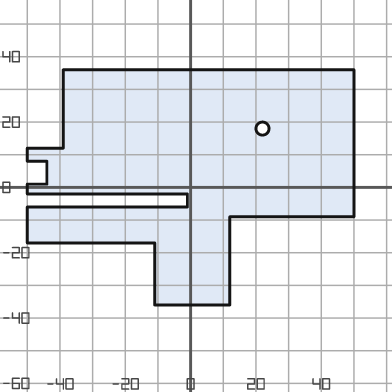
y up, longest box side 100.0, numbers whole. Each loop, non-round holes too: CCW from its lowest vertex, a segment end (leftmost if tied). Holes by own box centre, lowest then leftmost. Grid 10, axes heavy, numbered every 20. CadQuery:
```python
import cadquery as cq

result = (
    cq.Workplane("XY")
    .moveTo(-11.0, -36.0)
    .lineTo(12.0, -36.0)
    .lineTo(12.0, -9.0)
    .lineTo(50.0, -9.0)
    .lineTo(50.0, 36.0)
    .lineTo(-39.0, 36.0)
    .lineTo(-39.0, 12.0)
    .lineTo(-50.0, 12.0)
    .lineTo(-50.0, 8.0)
    .lineTo(-44.0, 8.0)
    .lineTo(-44.0, 1.0)
    .lineTo(-50.0, 1.0)
    .lineTo(-50.0, -2.0)
    .lineTo(-1.0, -2.0)
    .lineTo(-1.0, -6.0)
    .lineTo(-50.0, -6.0)
    .lineTo(-50.0, -17.0)
    .lineTo(-11.0, -17.0)
    .close()
    .moveTo(22.0, 18.0)
    .circle(2.0)
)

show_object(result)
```